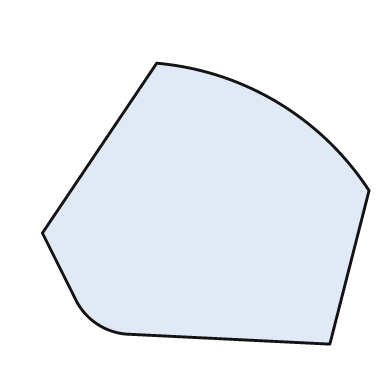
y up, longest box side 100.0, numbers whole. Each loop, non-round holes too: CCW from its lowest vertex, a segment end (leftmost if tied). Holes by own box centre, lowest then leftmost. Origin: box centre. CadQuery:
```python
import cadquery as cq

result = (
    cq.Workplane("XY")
    .moveTo(38.0, -43.0)
    .lineTo(50.0, 4.0)
    .threePointArc((22.0, 31.0), (-15.0, 43.0))
    .lineTo(-50.0, -9.0)
    .lineTo(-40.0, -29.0)
    .threePointArc((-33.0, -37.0), (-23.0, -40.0))
    .close()
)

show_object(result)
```